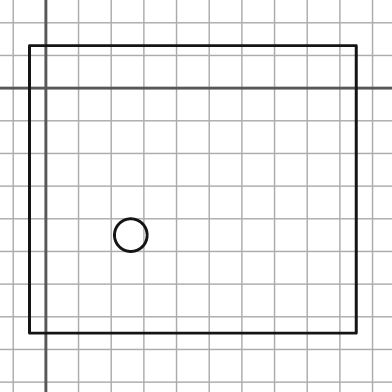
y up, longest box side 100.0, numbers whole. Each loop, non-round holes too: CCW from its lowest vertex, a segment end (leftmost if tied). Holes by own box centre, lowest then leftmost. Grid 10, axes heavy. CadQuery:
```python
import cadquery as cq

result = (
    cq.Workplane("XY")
    .moveTo(-5.0, -75.0)
    .lineTo(95.0, -75.0)
    .lineTo(95.0, 13.0)
    .lineTo(-5.0, 13.0)
    .close()
    .moveTo(26.0, -45.0)
    .circle(5.0)
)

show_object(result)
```